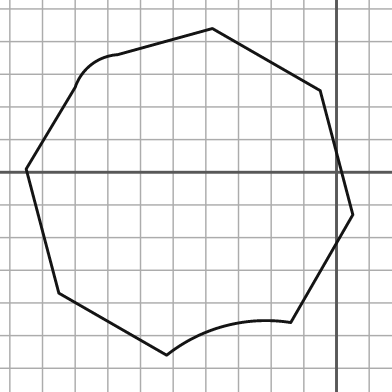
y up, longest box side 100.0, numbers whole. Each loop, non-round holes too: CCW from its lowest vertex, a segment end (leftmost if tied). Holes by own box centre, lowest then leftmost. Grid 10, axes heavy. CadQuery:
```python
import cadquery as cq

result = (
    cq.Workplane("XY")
    .moveTo(-52.0, -56.0)
    .threePointArc((-34.0, -47.0), (-14.0, -46.0))
    .lineTo(5.0, -13.0)
    .lineTo(-5.0, 25.0)
    .lineTo(-38.0, 44.0)
    .lineTo(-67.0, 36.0)
    .threePointArc((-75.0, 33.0), (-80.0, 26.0))
    .lineTo(-95.0, 1.0)
    .lineTo(-85.0, -37.0)
    .close()
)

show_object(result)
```